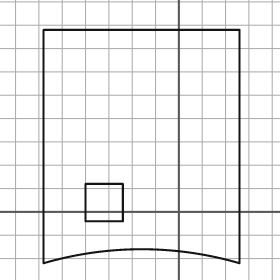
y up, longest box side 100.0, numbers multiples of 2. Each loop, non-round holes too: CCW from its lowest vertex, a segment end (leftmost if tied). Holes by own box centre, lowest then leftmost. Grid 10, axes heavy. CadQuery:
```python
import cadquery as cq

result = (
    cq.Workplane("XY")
    .moveTo(-58.0, -22.0)
    .threePointArc((-16.0, -16.0), (26.0, -22.0))
    .lineTo(26.0, 78.0)
    .lineTo(-58.0, 78.0)
    .close()
    .moveTo(-40.0, -4.0)
    .lineTo(-24.0, -4.0)
    .lineTo(-24.0, 12.0)
    .lineTo(-40.0, 12.0)
    .close()
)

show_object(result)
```